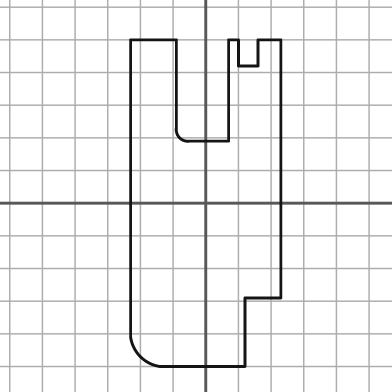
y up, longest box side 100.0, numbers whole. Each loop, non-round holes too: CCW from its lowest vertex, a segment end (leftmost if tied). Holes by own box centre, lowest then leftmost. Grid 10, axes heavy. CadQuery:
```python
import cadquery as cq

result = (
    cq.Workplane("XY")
    .moveTo(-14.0, -50.0)
    .lineTo(12.0, -50.0)
    .lineTo(12.0, -29.0)
    .lineTo(23.0, -29.0)
    .lineTo(23.0, 50.0)
    .lineTo(16.0, 50.0)
    .lineTo(16.0, 42.0)
    .lineTo(10.0, 42.0)
    .lineTo(10.0, 50.0)
    .lineTo(7.0, 50.0)
    .lineTo(7.0, 19.0)
    .lineTo(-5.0, 19.0)
    .threePointArc((-8.0, 20.0), (-9.0, 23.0))
    .lineTo(-9.0, 50.0)
    .lineTo(-23.0, 50.0)
    .lineTo(-23.0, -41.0)
    .threePointArc((-20.0, -47.0), (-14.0, -50.0))
    .close()
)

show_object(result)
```